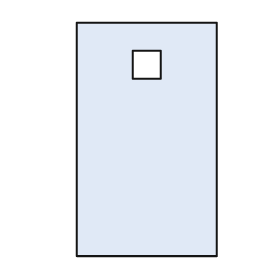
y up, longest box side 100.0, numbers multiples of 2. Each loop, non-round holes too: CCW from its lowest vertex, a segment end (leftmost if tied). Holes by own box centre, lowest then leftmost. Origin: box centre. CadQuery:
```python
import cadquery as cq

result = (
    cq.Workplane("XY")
    .moveTo(-30.0, -50.0)
    .lineTo(30.0, -50.0)
    .lineTo(30.0, 50.0)
    .lineTo(-30.0, 50.0)
    .close()
    .moveTo(-6.0, 26.0)
    .lineTo(6.0, 26.0)
    .lineTo(6.0, 38.0)
    .lineTo(-6.0, 38.0)
    .close()
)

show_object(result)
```